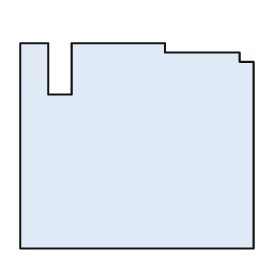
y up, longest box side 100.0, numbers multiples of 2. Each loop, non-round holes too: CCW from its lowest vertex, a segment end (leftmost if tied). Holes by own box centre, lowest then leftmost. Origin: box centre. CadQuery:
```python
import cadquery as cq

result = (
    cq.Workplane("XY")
    .moveTo(-50.0, -44.0)
    .lineTo(50.0, -44.0)
    .lineTo(50.0, 36.0)
    .lineTo(44.0, 36.0)
    .lineTo(44.0, 40.0)
    .lineTo(12.0, 40.0)
    .lineTo(12.0, 44.0)
    .lineTo(-28.0, 44.0)
    .lineTo(-28.0, 22.0)
    .lineTo(-38.0, 22.0)
    .lineTo(-38.0, 44.0)
    .lineTo(-50.0, 44.0)
    .close()
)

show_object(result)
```